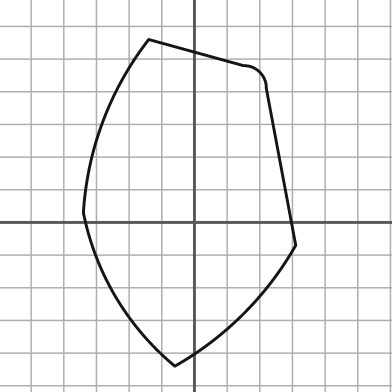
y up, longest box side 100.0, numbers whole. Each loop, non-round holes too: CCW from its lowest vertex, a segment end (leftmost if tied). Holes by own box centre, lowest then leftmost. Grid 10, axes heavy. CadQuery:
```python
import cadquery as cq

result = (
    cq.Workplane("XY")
    .moveTo(-6.0, -44.0)
    .threePointArc((15.0, -28.0), (31.0, -7.0))
    .lineTo(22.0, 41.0)
    .threePointArc((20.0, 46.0), (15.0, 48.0))
    .lineTo(-14.0, 56.0)
    .threePointArc((-28.0, 31.0), (-34.0, 3.0))
    .threePointArc((-24.0, -23.0), (-6.0, -44.0))
    .close()
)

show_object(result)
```